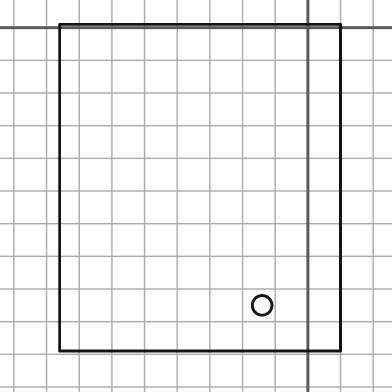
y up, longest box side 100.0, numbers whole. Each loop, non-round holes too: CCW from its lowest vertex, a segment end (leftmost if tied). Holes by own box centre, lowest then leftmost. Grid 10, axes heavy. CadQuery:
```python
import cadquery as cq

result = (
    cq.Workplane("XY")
    .moveTo(-76.0, -99.0)
    .lineTo(10.0, -99.0)
    .lineTo(10.0, 1.0)
    .lineTo(-76.0, 1.0)
    .close()
    .moveTo(-14.0, -85.0)
    .circle(3.0)
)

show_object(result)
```